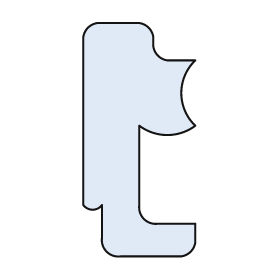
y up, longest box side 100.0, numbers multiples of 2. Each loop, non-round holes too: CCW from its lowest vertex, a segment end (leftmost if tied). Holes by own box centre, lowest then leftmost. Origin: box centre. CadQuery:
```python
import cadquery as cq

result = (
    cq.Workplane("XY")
    .moveTo(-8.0, -50.0)
    .lineTo(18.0, -50.0)
    .threePointArc((22.0, -48.0), (24.0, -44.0))
    .lineTo(24.0, -36.0)
    .lineTo(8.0, -36.0)
    .threePointArc((2.0, -34.0), (0.0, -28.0))
    .lineTo(0.0, 6.0)
    .threePointArc((12.0, 2.0), (24.0, 6.0))
    .threePointArc((18.0, 20.0), (24.0, 34.0))
    .lineTo(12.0, 34.0)
    .threePointArc((8.0, 36.0), (6.0, 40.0))
    .lineTo(6.0, 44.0)
    .threePointArc((4.0, 48.0), (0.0, 50.0))
    .lineTo(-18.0, 50.0)
    .threePointArc((-22.0, 48.0), (-24.0, 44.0))
    .lineTo(-24.0, -28.0)
    .threePointArc((-20.0, -30.0), (-16.0, -28.0))
    .lineTo(-16.0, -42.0)
    .threePointArc((-14.0, -48.0), (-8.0, -50.0))
    .close()
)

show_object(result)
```